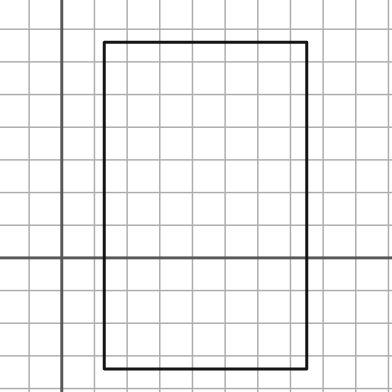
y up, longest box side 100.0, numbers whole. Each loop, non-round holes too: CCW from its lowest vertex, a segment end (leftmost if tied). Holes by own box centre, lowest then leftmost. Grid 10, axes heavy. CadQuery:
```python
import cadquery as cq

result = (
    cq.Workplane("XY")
    .moveTo(13.0, -34.0)
    .lineTo(75.0, -34.0)
    .lineTo(75.0, 66.0)
    .lineTo(13.0, 66.0)
    .close()
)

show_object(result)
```